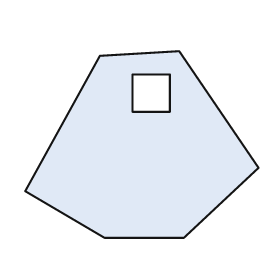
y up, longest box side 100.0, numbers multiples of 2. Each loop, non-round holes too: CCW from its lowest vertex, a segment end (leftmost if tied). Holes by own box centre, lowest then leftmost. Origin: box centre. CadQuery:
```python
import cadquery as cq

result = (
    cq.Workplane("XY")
    .moveTo(-16.0, -40.0)
    .lineTo(18.0, -40.0)
    .lineTo(50.0, -10.0)
    .lineTo(16.0, 40.0)
    .lineTo(-18.0, 38.0)
    .lineTo(-50.0, -20.0)
    .close()
    .moveTo(-4.0, 14.0)
    .lineTo(12.0, 14.0)
    .lineTo(12.0, 30.0)
    .lineTo(-4.0, 30.0)
    .close()
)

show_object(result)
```